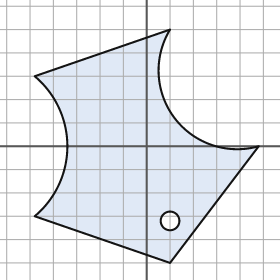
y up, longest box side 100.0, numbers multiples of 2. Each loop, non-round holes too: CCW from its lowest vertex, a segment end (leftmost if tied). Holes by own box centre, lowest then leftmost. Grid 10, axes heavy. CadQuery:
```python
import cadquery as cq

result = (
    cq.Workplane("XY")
    .moveTo(10.0, -50.0)
    .lineTo(48.0, 0.0)
    .threePointArc((12.0, 12.0), (10.0, 50.0))
    .lineTo(-48.0, 30.0)
    .threePointArc((-34.0, 0.0), (-48.0, -30.0))
    .close()
    .moveTo(10.0, -32.0)
    .circle(4.0)
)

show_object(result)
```